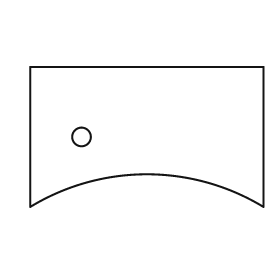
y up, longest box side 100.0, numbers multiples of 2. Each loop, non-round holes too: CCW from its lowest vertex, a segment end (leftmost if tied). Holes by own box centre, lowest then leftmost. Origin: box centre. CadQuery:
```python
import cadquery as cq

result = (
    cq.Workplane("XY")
    .moveTo(-50.0, -30.0)
    .threePointArc((0.0, -16.0), (50.0, -30.0))
    .lineTo(50.0, 30.0)
    .lineTo(-50.0, 30.0)
    .close()
    .moveTo(-28.0, 0.0)
    .circle(4.0)
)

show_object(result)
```